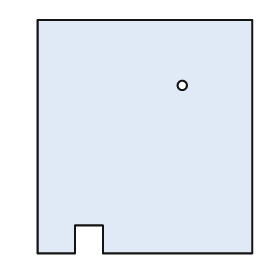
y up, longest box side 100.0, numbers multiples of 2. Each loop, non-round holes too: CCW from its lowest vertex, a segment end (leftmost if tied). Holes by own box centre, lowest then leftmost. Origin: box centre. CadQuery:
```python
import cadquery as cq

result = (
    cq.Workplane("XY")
    .moveTo(-46.0, -50.0)
    .lineTo(-30.0, -50.0)
    .lineTo(-30.0, -38.0)
    .lineTo(-18.0, -38.0)
    .lineTo(-18.0, -50.0)
    .lineTo(46.0, -50.0)
    .lineTo(46.0, 50.0)
    .lineTo(-46.0, 50.0)
    .close()
    .moveTo(16.0, 22.0)
    .circle(2.0)
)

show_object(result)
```